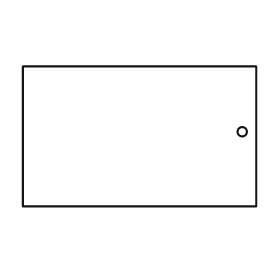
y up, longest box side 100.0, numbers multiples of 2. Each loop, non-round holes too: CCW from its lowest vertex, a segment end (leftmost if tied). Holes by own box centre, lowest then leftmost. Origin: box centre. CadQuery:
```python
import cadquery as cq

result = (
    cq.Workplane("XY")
    .moveTo(-50.0, -30.0)
    .lineTo(50.0, -30.0)
    .lineTo(50.0, 30.0)
    .lineTo(-50.0, 30.0)
    .close()
    .moveTo(44.0, 2.0)
    .circle(2.0)
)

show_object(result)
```